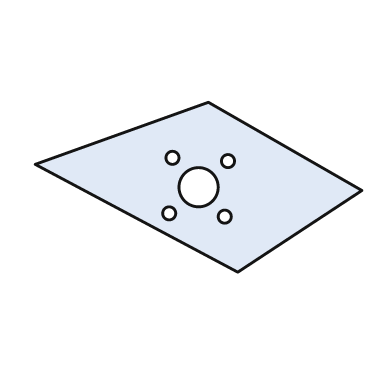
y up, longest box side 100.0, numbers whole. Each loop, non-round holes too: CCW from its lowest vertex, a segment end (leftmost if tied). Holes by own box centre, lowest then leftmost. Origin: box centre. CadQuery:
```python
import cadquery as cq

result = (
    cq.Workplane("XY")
    .moveTo(12.0, -26.0)
    .lineTo(50.0, -1.0)
    .lineTo(3.0, 26.0)
    .lineTo(-50.0, 7.0)
    .close()
    .moveTo(8.0, -9.0)
    .circle(2.0)
    .moveTo(-9.0, -8.0)
    .circle(2.0)
    .moveTo(0.0, 0.0)
    .circle(6.0)
    .moveTo(9.0, 8.0)
    .circle(2.0)
    .moveTo(-8.0, 9.0)
    .circle(2.0)
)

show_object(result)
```